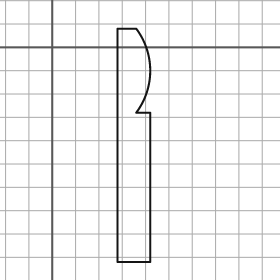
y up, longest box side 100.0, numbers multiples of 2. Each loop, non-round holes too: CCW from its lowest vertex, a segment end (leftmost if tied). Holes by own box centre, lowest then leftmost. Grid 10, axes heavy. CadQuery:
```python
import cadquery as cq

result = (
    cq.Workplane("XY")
    .moveTo(28.0, -92.0)
    .lineTo(42.0, -92.0)
    .lineTo(42.0, -28.0)
    .lineTo(36.0, -28.0)
    .threePointArc((42.0, -10.0), (36.0, 8.0))
    .lineTo(28.0, 8.0)
    .close()
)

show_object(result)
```